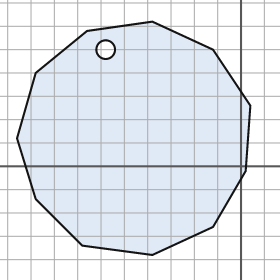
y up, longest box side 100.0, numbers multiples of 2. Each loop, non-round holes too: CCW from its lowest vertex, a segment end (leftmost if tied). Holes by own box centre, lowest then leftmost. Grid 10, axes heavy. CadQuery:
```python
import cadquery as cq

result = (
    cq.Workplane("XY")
    .moveTo(-38.0, -38.0)
    .lineTo(-12.0, -26.0)
    .lineTo(2.0, -2.0)
    .lineTo(4.0, 26.0)
    .lineTo(-12.0, 50.0)
    .lineTo(-38.0, 62.0)
    .lineTo(-66.0, 58.0)
    .lineTo(-88.0, 40.0)
    .lineTo(-96.0, 12.0)
    .lineTo(-88.0, -14.0)
    .lineTo(-68.0, -34.0)
    .close()
    .moveTo(-58.0, 50.0)
    .circle(4.0)
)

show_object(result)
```